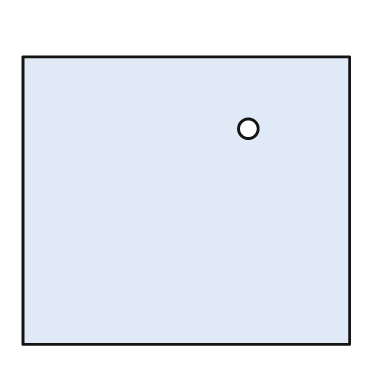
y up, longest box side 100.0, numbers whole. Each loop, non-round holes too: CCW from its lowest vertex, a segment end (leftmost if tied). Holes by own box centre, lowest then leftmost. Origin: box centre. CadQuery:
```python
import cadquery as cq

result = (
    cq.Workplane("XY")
    .moveTo(-50.0, -44.0)
    .lineTo(50.0, -44.0)
    .lineTo(50.0, 44.0)
    .lineTo(-50.0, 44.0)
    .close()
    .moveTo(19.0, 22.0)
    .circle(3.0)
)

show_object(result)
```